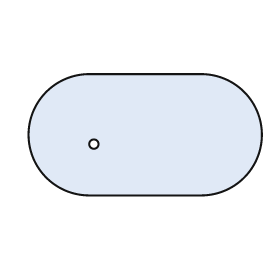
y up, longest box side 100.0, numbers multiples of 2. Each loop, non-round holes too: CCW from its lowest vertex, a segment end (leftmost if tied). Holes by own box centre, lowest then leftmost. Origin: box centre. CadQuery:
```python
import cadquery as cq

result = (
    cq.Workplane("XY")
    .moveTo(-24.0, -26.0)
    .lineTo(24.0, -26.0)
    .threePointArc((50.0, 0.0), (24.0, 26.0))
    .lineTo(-24.0, 26.0)
    .threePointArc((-50.0, 0.0), (-24.0, -26.0))
    .close()
    .moveTo(-22.0, -4.0)
    .circle(2.0)
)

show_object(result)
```